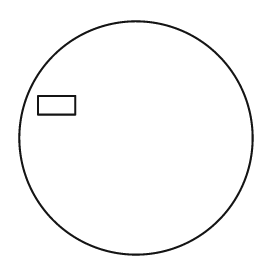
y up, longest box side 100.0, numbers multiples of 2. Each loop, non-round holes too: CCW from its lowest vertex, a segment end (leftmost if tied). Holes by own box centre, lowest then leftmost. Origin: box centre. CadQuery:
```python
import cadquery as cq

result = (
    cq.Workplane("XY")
    .moveTo(0.0, 0.0)
    .circle(50.0)
    .moveTo(-42.0, 10.0)
    .lineTo(-26.0, 10.0)
    .lineTo(-26.0, 18.0)
    .lineTo(-42.0, 18.0)
    .close()
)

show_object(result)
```